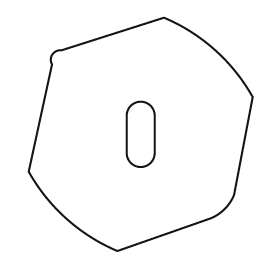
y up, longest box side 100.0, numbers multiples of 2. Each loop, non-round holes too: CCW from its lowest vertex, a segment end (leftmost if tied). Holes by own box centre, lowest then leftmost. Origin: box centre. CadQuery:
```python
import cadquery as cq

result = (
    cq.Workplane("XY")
    .moveTo(-10.0, -50.0)
    .lineTo(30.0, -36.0)
    .threePointArc((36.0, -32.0), (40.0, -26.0))
    .lineTo(48.0, 16.0)
    .threePointArc((32.0, 36.0), (10.0, 50.0))
    .lineTo(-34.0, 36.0)
    .threePointArc((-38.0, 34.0), (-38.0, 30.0))
    .lineTo(-48.0, -16.0)
    .threePointArc((-32.0, -36.0), (-10.0, -50.0))
    .close()
    .moveTo(-6.0, -8.0)
    .threePointArc((0.0, -14.0), (6.0, -8.0))
    .lineTo(6.0, 8.0)
    .threePointArc((0.0, 14.0), (-6.0, 8.0))
    .close()
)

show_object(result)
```